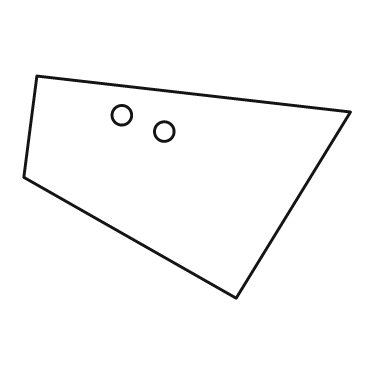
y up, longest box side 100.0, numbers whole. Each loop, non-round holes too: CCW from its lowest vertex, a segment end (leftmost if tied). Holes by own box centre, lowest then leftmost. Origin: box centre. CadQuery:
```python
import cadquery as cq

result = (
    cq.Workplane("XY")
    .moveTo(15.0, -34.0)
    .lineTo(50.0, 23.0)
    .lineTo(-46.0, 34.0)
    .lineTo(-50.0, 3.0)
    .close()
    .moveTo(-7.0, 17.0)
    .circle(3.0)
    .moveTo(-20.0, 22.0)
    .circle(3.0)
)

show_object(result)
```